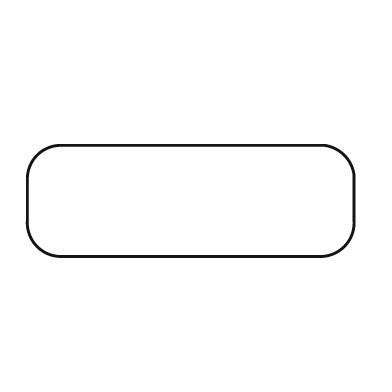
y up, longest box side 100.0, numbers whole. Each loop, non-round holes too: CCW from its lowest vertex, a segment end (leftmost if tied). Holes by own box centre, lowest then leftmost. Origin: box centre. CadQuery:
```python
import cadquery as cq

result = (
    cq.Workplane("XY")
    .moveTo(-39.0, -17.0)
    .lineTo(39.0, -17.0)
    .threePointArc((47.0, -14.0), (50.0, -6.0))
    .lineTo(50.0, 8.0)
    .threePointArc((47.0, 14.0), (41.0, 17.0))
    .lineTo(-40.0, 17.0)
    .threePointArc((-47.0, 14.0), (-50.0, 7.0))
    .lineTo(-50.0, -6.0)
    .threePointArc((-47.0, -14.0), (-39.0, -17.0))
    .close()
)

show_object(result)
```